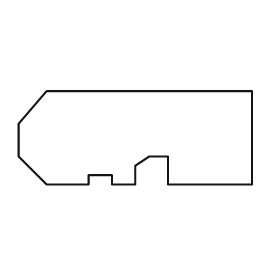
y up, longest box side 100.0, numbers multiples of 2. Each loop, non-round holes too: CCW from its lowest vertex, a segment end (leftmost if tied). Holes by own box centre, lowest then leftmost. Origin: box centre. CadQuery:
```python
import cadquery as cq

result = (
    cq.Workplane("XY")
    .moveTo(-38.0, -20.0)
    .lineTo(-20.0, -20.0)
    .lineTo(-20.0, -16.0)
    .lineTo(-10.0, -16.0)
    .lineTo(-10.0, -20.0)
    .lineTo(0.0, -20.0)
    .lineTo(0.0, -12.0)
    .lineTo(6.0, -8.0)
    .lineTo(14.0, -8.0)
    .lineTo(14.0, -20.0)
    .lineTo(50.0, -20.0)
    .lineTo(50.0, 20.0)
    .lineTo(-38.0, 20.0)
    .lineTo(-50.0, 6.0)
    .lineTo(-50.0, -8.0)
    .close()
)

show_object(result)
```